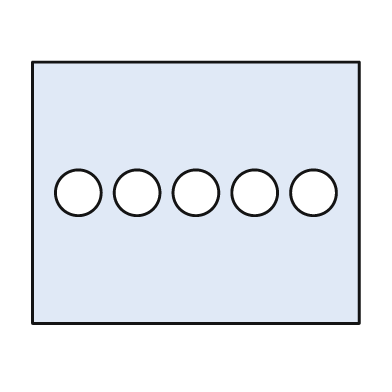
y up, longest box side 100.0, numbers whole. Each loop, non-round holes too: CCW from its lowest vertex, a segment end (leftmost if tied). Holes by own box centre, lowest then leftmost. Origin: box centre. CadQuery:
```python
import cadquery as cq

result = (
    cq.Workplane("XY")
    .moveTo(-50.0, -40.0)
    .lineTo(50.0, -40.0)
    .lineTo(50.0, 40.0)
    .lineTo(-50.0, 40.0)
    .close()
    .moveTo(-36.0, 0.0)
    .circle(7.0)
    .moveTo(-18.0, 0.0)
    .circle(7.0)
    .moveTo(0.0, 0.0)
    .circle(7.0)
    .moveTo(18.0, 0.0)
    .circle(7.0)
    .moveTo(36.0, 0.0)
    .circle(7.0)
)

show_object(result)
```